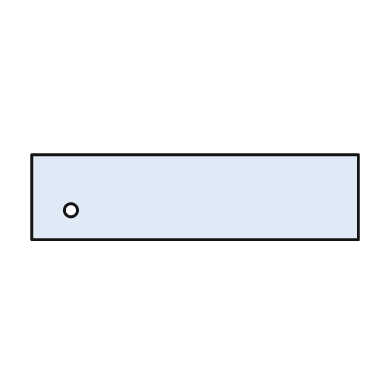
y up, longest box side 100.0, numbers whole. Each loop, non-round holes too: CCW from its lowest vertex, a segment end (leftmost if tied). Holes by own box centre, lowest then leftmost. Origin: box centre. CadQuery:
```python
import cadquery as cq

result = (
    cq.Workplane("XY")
    .moveTo(-50.0, -13.0)
    .lineTo(50.0, -13.0)
    .lineTo(50.0, 13.0)
    .lineTo(-50.0, 13.0)
    .close()
    .moveTo(-38.0, -4.0)
    .circle(2.0)
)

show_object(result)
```